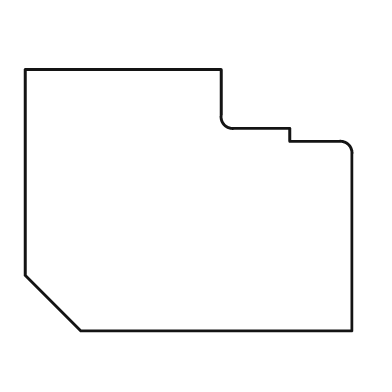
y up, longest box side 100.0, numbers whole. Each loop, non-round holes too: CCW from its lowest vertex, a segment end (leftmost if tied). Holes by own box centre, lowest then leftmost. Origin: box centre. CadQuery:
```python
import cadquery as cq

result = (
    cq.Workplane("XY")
    .moveTo(-33.0, -40.0)
    .lineTo(50.0, -40.0)
    .lineTo(50.0, 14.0)
    .threePointArc((49.0, 17.0), (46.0, 18.0))
    .lineTo(31.0, 18.0)
    .lineTo(31.0, 22.0)
    .lineTo(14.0, 22.0)
    .threePointArc((11.0, 23.0), (10.0, 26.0))
    .lineTo(10.0, 40.0)
    .lineTo(-50.0, 40.0)
    .lineTo(-50.0, -23.0)
    .close()
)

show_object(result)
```